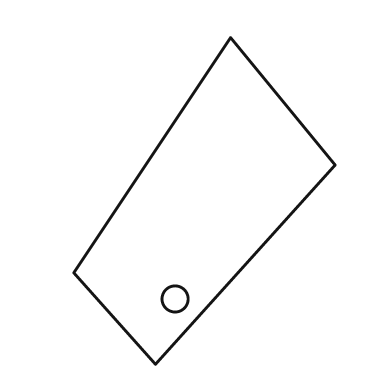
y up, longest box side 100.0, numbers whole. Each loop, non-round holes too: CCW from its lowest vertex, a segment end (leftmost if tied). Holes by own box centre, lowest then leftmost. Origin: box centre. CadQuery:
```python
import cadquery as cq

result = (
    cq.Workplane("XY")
    .moveTo(-15.0, -50.0)
    .lineTo(40.0, 11.0)
    .lineTo(8.0, 50.0)
    .lineTo(-40.0, -22.0)
    .close()
    .moveTo(-9.0, -30.0)
    .circle(4.0)
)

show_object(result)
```